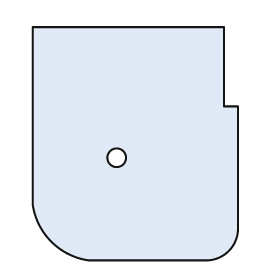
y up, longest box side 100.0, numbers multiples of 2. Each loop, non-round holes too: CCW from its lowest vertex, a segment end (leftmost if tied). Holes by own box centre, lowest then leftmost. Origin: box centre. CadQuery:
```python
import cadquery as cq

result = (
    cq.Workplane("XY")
    .moveTo(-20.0, -50.0)
    .lineTo(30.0, -50.0)
    .threePointArc((40.0, -46.0), (44.0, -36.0))
    .lineTo(44.0, 16.0)
    .lineTo(38.0, 16.0)
    .lineTo(38.0, 50.0)
    .lineTo(-44.0, 50.0)
    .lineTo(-44.0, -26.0)
    .threePointArc((-36.0, -42.0), (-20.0, -50.0))
    .close()
    .moveTo(-8.0, -6.0)
    .circle(4.0)
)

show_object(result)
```